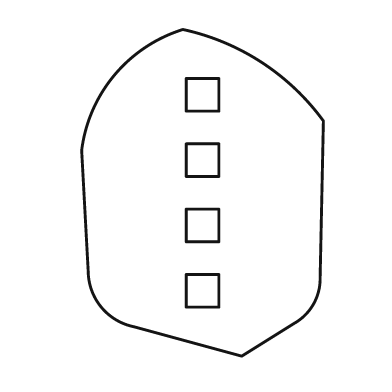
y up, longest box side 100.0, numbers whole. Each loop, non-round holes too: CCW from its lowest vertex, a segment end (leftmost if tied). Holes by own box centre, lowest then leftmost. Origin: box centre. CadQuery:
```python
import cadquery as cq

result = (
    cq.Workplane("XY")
    .moveTo(12.0, -50.0)
    .lineTo(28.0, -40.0)
    .threePointArc((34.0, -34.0), (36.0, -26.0))
    .lineTo(37.0, 22.0)
    .threePointArc((18.0, 40.0), (-6.0, 50.0))
    .threePointArc((-27.0, 36.0), (-37.0, 13.0))
    .lineTo(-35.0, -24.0)
    .threePointArc((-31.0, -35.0), (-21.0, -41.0))
    .close()
    .moveTo(-5.0, -35.0)
    .lineTo(5.0, -35.0)
    .lineTo(5.0, -25.0)
    .lineTo(-5.0, -25.0)
    .close()
    .moveTo(-5.0, -15.0)
    .lineTo(5.0, -15.0)
    .lineTo(5.0, -5.0)
    .lineTo(-5.0, -5.0)
    .close()
    .moveTo(-5.0, 5.0)
    .lineTo(5.0, 5.0)
    .lineTo(5.0, 15.0)
    .lineTo(-5.0, 15.0)
    .close()
    .moveTo(-5.0, 25.0)
    .lineTo(5.0, 25.0)
    .lineTo(5.0, 35.0)
    .lineTo(-5.0, 35.0)
    .close()
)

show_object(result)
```